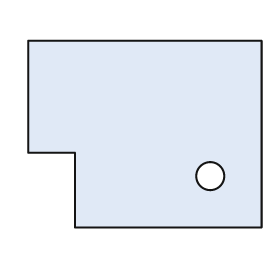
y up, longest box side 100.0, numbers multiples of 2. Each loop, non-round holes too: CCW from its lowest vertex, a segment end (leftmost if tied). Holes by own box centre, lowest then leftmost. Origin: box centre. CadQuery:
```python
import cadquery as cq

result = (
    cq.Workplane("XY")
    .moveTo(-30.0, -40.0)
    .lineTo(50.0, -40.0)
    .lineTo(50.0, 40.0)
    .lineTo(-50.0, 40.0)
    .lineTo(-50.0, -8.0)
    .lineTo(-30.0, -8.0)
    .close()
    .moveTo(28.0, -18.0)
    .circle(6.0)
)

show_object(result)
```